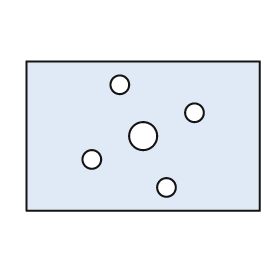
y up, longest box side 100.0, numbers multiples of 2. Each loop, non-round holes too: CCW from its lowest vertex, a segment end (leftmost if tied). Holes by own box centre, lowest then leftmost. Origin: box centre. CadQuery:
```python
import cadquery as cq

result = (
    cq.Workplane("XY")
    .moveTo(-50.0, -32.0)
    .lineTo(50.0, -32.0)
    .lineTo(50.0, 32.0)
    .lineTo(-50.0, 32.0)
    .close()
    .moveTo(10.0, -22.0)
    .circle(4.0)
    .moveTo(-22.0, -10.0)
    .circle(4.0)
    .moveTo(0.0, 0.0)
    .circle(6.0)
    .moveTo(22.0, 10.0)
    .circle(4.0)
    .moveTo(-10.0, 22.0)
    .circle(4.0)
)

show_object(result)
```